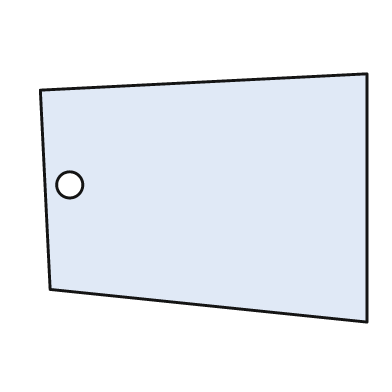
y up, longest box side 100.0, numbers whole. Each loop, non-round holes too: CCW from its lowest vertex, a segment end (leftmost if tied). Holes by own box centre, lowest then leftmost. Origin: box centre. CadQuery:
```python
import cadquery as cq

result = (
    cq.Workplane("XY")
    .moveTo(50.0, -38.0)
    .lineTo(50.0, 38.0)
    .lineTo(-50.0, 33.0)
    .lineTo(-47.0, -28.0)
    .close()
    .moveTo(-41.0, 4.0)
    .circle(4.0)
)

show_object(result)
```